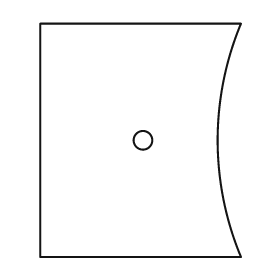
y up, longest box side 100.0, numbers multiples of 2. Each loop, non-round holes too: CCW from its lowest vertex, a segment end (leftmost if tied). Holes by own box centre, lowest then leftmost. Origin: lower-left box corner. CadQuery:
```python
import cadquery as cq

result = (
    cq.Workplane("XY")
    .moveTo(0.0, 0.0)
    .lineTo(86.0, 0.0)
    .threePointArc((76.0, 50.0), (86.0, 100.0))
    .lineTo(0.0, 100.0)
    .close()
    .moveTo(44.0, 50.0)
    .circle(4.0)
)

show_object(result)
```